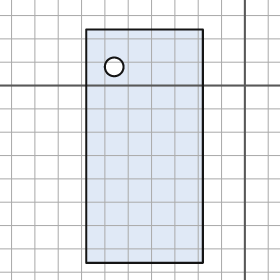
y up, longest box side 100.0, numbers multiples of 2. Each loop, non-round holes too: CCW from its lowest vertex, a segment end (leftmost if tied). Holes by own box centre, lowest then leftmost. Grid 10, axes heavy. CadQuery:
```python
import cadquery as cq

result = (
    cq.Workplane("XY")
    .moveTo(-68.0, -76.0)
    .lineTo(-18.0, -76.0)
    .lineTo(-18.0, 24.0)
    .lineTo(-68.0, 24.0)
    .close()
    .moveTo(-56.0, 8.0)
    .circle(4.0)
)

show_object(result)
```